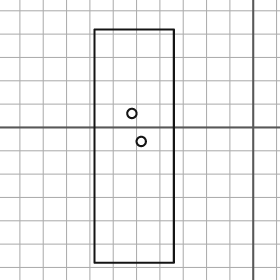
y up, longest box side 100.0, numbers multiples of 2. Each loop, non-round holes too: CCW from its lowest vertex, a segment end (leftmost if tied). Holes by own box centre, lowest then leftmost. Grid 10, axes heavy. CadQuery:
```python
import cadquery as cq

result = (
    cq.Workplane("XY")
    .moveTo(-68.0, -58.0)
    .lineTo(-34.0, -58.0)
    .lineTo(-34.0, 42.0)
    .lineTo(-68.0, 42.0)
    .close()
    .moveTo(-48.0, -6.0)
    .circle(2.0)
    .moveTo(-52.0, 6.0)
    .circle(2.0)
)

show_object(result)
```